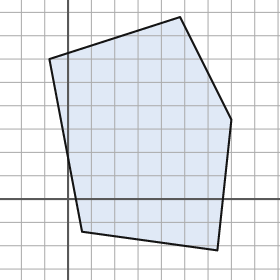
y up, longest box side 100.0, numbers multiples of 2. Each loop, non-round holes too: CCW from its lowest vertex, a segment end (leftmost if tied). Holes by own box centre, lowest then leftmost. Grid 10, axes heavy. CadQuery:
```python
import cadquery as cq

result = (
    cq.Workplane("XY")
    .moveTo(64.0, -22.0)
    .lineTo(70.0, 34.0)
    .lineTo(48.0, 78.0)
    .lineTo(-8.0, 60.0)
    .lineTo(6.0, -14.0)
    .close()
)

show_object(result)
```